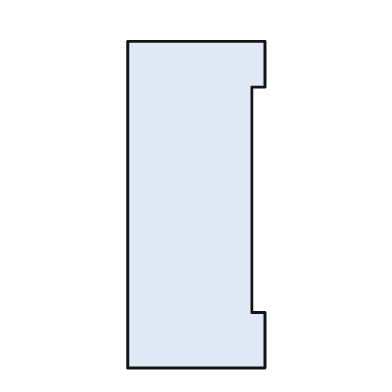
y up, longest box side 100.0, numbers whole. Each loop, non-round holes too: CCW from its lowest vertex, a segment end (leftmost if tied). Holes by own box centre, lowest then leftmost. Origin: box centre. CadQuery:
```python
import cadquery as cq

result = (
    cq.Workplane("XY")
    .moveTo(-21.0, -50.0)
    .lineTo(21.0, -50.0)
    .lineTo(21.0, -33.0)
    .lineTo(17.0, -33.0)
    .lineTo(17.0, 36.0)
    .lineTo(21.0, 36.0)
    .lineTo(21.0, 50.0)
    .lineTo(-21.0, 50.0)
    .close()
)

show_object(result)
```